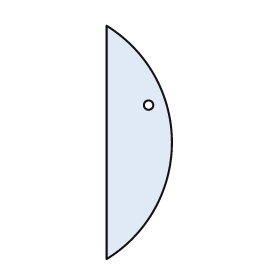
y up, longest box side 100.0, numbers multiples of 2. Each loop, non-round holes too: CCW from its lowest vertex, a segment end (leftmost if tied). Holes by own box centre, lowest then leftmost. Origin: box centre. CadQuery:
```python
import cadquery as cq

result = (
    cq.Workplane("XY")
    .moveTo(-14.0, -50.0)
    .threePointArc((14.0, 0.0), (-14.0, 50.0))
    .close()
    .moveTo(4.0, 16.0)
    .circle(2.0)
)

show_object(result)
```